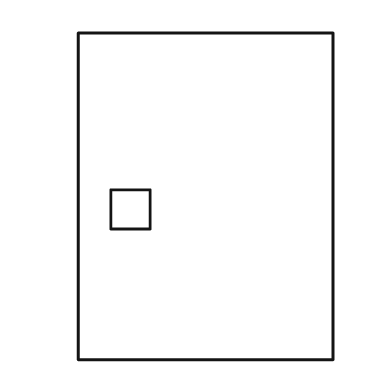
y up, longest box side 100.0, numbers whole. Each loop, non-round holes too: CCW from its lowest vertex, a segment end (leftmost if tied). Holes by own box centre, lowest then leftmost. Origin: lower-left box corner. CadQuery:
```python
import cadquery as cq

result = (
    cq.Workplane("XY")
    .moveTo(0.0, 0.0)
    .lineTo(78.0, 0.0)
    .lineTo(78.0, 100.0)
    .lineTo(0.0, 100.0)
    .close()
    .moveTo(10.0, 40.0)
    .lineTo(22.0, 40.0)
    .lineTo(22.0, 52.0)
    .lineTo(10.0, 52.0)
    .close()
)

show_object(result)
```